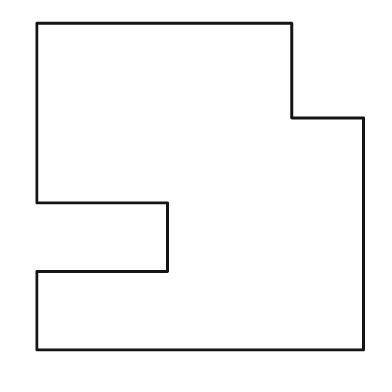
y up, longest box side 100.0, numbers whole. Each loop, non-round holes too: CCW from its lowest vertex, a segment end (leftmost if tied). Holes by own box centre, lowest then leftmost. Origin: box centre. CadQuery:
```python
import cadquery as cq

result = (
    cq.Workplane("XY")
    .moveTo(-50.0, -50.0)
    .lineTo(50.0, -50.0)
    .lineTo(50.0, 21.0)
    .lineTo(28.0, 21.0)
    .lineTo(28.0, 50.0)
    .lineTo(-50.0, 50.0)
    .lineTo(-50.0, -5.0)
    .lineTo(-10.0, -5.0)
    .lineTo(-10.0, -26.0)
    .lineTo(-50.0, -26.0)
    .close()
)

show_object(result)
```